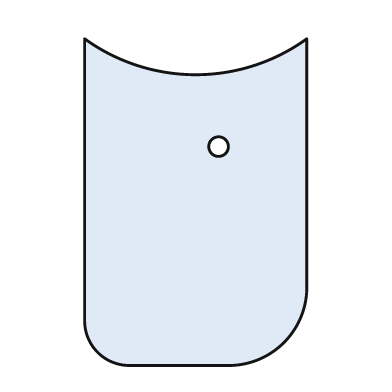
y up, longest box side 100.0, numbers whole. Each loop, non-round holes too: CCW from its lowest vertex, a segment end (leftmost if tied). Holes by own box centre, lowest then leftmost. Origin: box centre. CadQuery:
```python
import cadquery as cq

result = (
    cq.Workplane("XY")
    .moveTo(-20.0, -50.0)
    .lineTo(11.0, -50.0)
    .threePointArc((27.0, -43.0), (34.0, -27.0))
    .lineTo(34.0, 50.0)
    .threePointArc((0.0, 39.0), (-34.0, 50.0))
    .lineTo(-34.0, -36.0)
    .threePointArc((-30.0, -46.0), (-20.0, -50.0))
    .close()
    .moveTo(7.0, 17.0)
    .circle(3.0)
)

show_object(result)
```